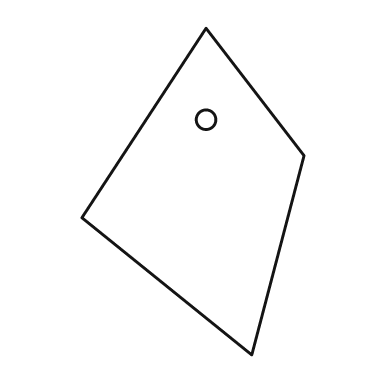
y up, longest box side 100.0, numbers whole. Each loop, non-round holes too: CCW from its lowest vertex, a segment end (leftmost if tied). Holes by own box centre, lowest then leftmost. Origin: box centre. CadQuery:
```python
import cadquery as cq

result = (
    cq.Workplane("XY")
    .moveTo(18.0, -50.0)
    .lineTo(34.0, 11.0)
    .lineTo(4.0, 50.0)
    .lineTo(-34.0, -8.0)
    .close()
    .moveTo(4.0, 22.0)
    .circle(3.0)
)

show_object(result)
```